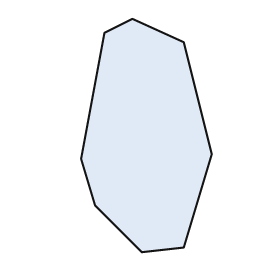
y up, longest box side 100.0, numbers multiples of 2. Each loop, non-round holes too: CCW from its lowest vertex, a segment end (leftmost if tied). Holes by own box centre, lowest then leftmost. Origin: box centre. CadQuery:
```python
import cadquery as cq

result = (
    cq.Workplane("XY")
    .moveTo(-2.0, -50.0)
    .lineTo(16.0, -48.0)
    .lineTo(28.0, -8.0)
    .lineTo(16.0, 40.0)
    .lineTo(-6.0, 50.0)
    .lineTo(-18.0, 44.0)
    .lineTo(-28.0, -10.0)
    .lineTo(-22.0, -30.0)
    .close()
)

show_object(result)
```